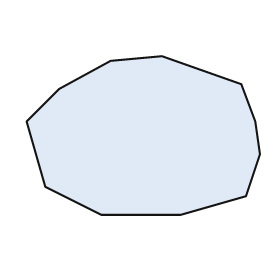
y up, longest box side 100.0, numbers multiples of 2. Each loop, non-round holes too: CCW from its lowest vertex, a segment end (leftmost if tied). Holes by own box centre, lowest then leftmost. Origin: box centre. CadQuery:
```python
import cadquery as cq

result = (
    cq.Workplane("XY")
    .moveTo(-18.0, -34.0)
    .lineTo(16.0, -34.0)
    .lineTo(44.0, -26.0)
    .lineTo(50.0, -8.0)
    .lineTo(48.0, 6.0)
    .lineTo(42.0, 22.0)
    .lineTo(8.0, 34.0)
    .lineTo(-14.0, 32.0)
    .lineTo(-36.0, 20.0)
    .lineTo(-50.0, 6.0)
    .lineTo(-42.0, -22.0)
    .close()
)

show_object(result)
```